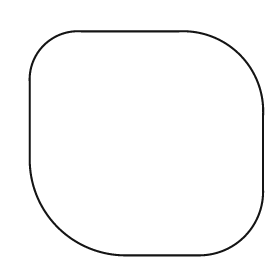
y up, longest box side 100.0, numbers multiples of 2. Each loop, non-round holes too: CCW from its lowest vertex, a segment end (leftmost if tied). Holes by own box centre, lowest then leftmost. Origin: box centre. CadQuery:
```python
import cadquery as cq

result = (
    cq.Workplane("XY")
    .moveTo(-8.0, -48.0)
    .lineTo(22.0, -48.0)
    .threePointArc((42.0, -40.0), (50.0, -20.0))
    .lineTo(50.0, 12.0)
    .threePointArc((40.0, 38.0), (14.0, 48.0))
    .lineTo(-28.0, 48.0)
    .threePointArc((-44.0, 42.0), (-50.0, 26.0))
    .lineTo(-50.0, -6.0)
    .threePointArc((-38.0, -36.0), (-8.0, -48.0))
    .close()
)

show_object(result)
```